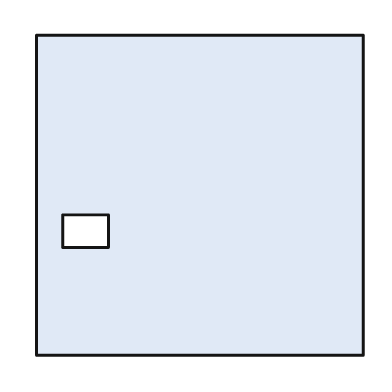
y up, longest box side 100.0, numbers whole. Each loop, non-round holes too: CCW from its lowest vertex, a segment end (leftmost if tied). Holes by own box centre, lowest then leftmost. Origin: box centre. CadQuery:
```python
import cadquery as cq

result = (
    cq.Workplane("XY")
    .moveTo(-50.0, -49.0)
    .lineTo(50.0, -49.0)
    .lineTo(50.0, 49.0)
    .lineTo(-50.0, 49.0)
    .close()
    .moveTo(-42.0, -16.0)
    .lineTo(-28.0, -16.0)
    .lineTo(-28.0, -6.0)
    .lineTo(-42.0, -6.0)
    .close()
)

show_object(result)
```